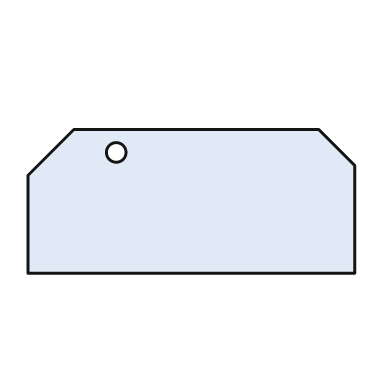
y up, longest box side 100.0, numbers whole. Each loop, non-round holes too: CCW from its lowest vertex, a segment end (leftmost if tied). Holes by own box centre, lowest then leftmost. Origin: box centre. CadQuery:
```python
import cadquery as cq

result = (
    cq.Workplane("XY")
    .moveTo(-50.0, -22.0)
    .lineTo(50.0, -22.0)
    .lineTo(50.0, 11.0)
    .lineTo(39.0, 22.0)
    .lineTo(-36.0, 22.0)
    .lineTo(-50.0, 8.0)
    .close()
    .moveTo(-23.0, 15.0)
    .circle(3.0)
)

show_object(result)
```